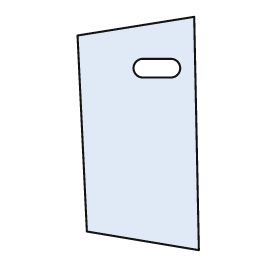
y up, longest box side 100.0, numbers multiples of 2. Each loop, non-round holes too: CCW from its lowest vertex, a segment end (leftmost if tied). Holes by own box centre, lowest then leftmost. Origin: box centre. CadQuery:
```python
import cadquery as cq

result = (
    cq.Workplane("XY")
    .moveTo(26.0, -50.0)
    .lineTo(24.0, 50.0)
    .lineTo(-26.0, 42.0)
    .lineTo(-22.0, -42.0)
    .close()
    .moveTo(2.0, 24.0)
    .lineTo(14.0, 24.0)
    .threePointArc((18.0, 28.0), (14.0, 32.0))
    .lineTo(2.0, 32.0)
    .threePointArc((-2.0, 28.0), (2.0, 24.0))
    .close()
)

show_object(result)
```